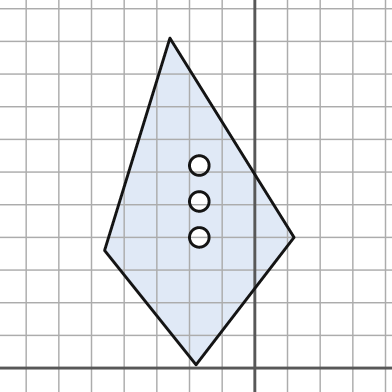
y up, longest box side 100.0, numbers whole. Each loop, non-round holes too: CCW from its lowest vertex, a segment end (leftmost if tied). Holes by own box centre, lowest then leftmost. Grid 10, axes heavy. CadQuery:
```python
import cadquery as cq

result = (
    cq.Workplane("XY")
    .moveTo(-18.0, 1.0)
    .lineTo(12.0, 40.0)
    .lineTo(-26.0, 101.0)
    .lineTo(-46.0, 36.0)
    .close()
    .moveTo(-17.0, 40.0)
    .circle(3.0)
    .moveTo(-17.0, 51.0)
    .circle(3.0)
    .moveTo(-17.0, 62.0)
    .circle(3.0)
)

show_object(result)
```